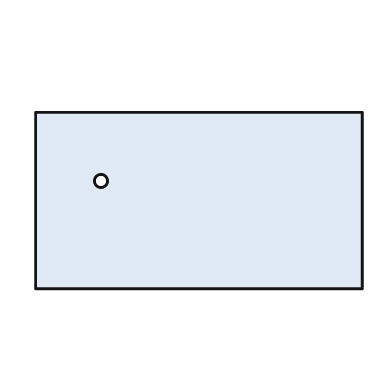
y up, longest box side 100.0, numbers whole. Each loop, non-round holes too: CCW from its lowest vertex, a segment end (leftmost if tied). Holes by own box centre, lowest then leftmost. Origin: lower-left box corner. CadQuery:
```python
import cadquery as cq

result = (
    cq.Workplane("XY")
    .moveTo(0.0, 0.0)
    .lineTo(100.0, 0.0)
    .lineTo(100.0, 54.0)
    .lineTo(0.0, 54.0)
    .close()
    .moveTo(20.0, 33.0)
    .circle(2.0)
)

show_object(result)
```